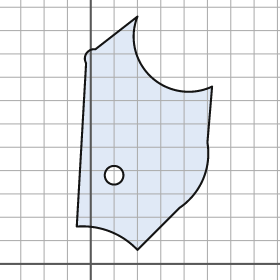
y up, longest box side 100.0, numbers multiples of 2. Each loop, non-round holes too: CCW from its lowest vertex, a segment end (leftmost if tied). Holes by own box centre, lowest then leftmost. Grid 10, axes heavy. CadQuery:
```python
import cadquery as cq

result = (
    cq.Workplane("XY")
    .moveTo(20.0, 6.0)
    .lineTo(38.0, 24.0)
    .threePointArc((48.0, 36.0), (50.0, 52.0))
    .lineTo(52.0, 76.0)
    .threePointArc((26.0, 80.0), (20.0, 106.0))
    .lineTo(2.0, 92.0)
    .threePointArc((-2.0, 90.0), (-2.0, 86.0))
    .lineTo(-6.0, 16.0)
    .threePointArc((8.0, 14.0), (20.0, 6.0))
    .close()
    .moveTo(10.0, 38.0)
    .circle(4.0)
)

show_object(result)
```